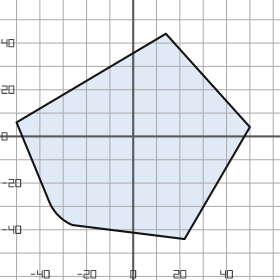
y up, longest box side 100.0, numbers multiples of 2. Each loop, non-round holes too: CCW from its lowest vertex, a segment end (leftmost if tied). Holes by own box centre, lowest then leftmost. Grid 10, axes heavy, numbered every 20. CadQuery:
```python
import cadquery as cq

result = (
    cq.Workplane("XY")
    .moveTo(22.0, -44.0)
    .lineTo(50.0, 4.0)
    .lineTo(14.0, 44.0)
    .lineTo(-50.0, 6.0)
    .lineTo(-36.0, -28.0)
    .threePointArc((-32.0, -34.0), (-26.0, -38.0))
    .close()
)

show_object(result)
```